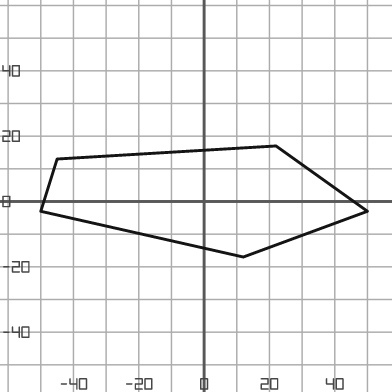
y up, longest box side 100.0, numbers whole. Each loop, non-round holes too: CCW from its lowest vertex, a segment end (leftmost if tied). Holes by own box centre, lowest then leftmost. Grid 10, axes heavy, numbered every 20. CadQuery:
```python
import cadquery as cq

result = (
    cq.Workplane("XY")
    .moveTo(12.0, -17.0)
    .lineTo(50.0, -3.0)
    .lineTo(22.0, 17.0)
    .lineTo(-45.0, 13.0)
    .lineTo(-50.0, -3.0)
    .close()
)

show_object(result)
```